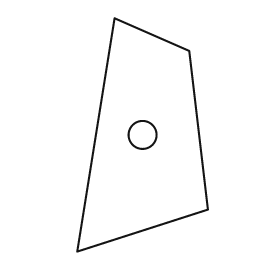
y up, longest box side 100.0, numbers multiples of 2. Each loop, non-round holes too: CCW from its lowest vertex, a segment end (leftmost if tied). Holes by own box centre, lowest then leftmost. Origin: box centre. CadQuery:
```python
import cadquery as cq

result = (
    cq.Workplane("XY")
    .moveTo(-28.0, -50.0)
    .lineTo(28.0, -32.0)
    .lineTo(20.0, 36.0)
    .lineTo(-12.0, 50.0)
    .close()
    .moveTo(0.0, 0.0)
    .circle(6.0)
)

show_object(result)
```